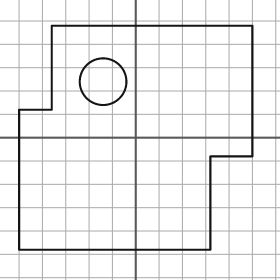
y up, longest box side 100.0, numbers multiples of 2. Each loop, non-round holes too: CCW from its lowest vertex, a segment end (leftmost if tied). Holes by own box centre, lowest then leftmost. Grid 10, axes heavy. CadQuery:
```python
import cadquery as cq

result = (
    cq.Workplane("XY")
    .moveTo(-50.0, -48.0)
    .lineTo(32.0, -48.0)
    .lineTo(32.0, -8.0)
    .lineTo(50.0, -8.0)
    .lineTo(50.0, 48.0)
    .lineTo(-36.0, 48.0)
    .lineTo(-36.0, 12.0)
    .lineTo(-50.0, 12.0)
    .close()
    .moveTo(-14.0, 24.0)
    .circle(10.0)
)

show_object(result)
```